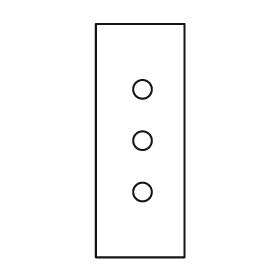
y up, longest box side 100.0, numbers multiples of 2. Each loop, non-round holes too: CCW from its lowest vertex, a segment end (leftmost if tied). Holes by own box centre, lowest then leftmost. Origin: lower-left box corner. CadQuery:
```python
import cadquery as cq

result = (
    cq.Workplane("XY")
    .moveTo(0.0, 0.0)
    .lineTo(38.0, 0.0)
    .lineTo(38.0, 100.0)
    .lineTo(0.0, 100.0)
    .close()
    .moveTo(20.0, 28.0)
    .circle(4.0)
    .moveTo(20.0, 50.0)
    .circle(4.0)
    .moveTo(20.0, 72.0)
    .circle(4.0)
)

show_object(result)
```